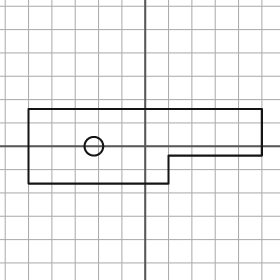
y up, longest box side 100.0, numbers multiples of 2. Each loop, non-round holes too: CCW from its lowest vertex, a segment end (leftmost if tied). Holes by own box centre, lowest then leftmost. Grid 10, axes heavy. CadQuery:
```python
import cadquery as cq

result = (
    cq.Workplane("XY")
    .moveTo(-50.0, -16.0)
    .lineTo(10.0, -16.0)
    .lineTo(10.0, -4.0)
    .lineTo(50.0, -4.0)
    .lineTo(50.0, 16.0)
    .lineTo(-50.0, 16.0)
    .close()
    .moveTo(-22.0, 0.0)
    .circle(4.0)
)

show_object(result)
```